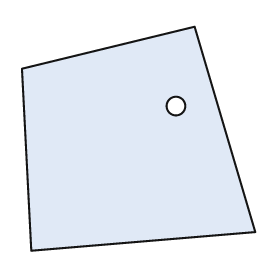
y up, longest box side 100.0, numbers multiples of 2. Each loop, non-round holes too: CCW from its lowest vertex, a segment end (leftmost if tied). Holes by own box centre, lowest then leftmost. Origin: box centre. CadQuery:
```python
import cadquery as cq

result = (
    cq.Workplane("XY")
    .moveTo(-46.0, -48.0)
    .lineTo(50.0, -40.0)
    .lineTo(24.0, 48.0)
    .lineTo(-50.0, 30.0)
    .close()
    .moveTo(16.0, 14.0)
    .circle(4.0)
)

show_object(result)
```